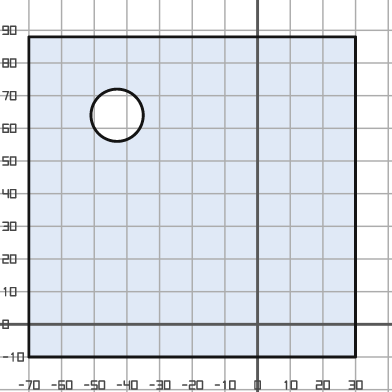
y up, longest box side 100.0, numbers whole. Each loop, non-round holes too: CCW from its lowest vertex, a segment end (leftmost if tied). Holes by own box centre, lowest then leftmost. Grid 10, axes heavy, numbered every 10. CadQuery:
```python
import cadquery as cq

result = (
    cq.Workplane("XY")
    .moveTo(-70.0, -10.0)
    .lineTo(30.0, -10.0)
    .lineTo(30.0, 88.0)
    .lineTo(-70.0, 88.0)
    .close()
    .moveTo(-43.0, 64.0)
    .circle(8.0)
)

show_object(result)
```